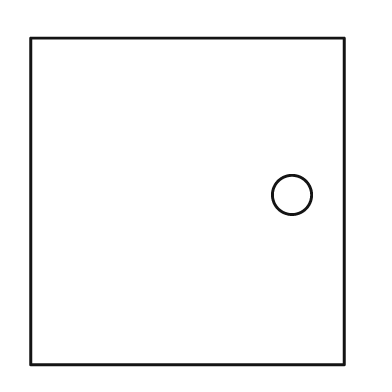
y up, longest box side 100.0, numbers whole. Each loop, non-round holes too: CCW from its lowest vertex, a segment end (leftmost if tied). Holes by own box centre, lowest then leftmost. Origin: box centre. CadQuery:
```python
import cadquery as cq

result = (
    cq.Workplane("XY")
    .moveTo(-48.0, -50.0)
    .lineTo(48.0, -50.0)
    .lineTo(48.0, 50.0)
    .lineTo(-48.0, 50.0)
    .close()
    .moveTo(32.0, 2.0)
    .circle(6.0)
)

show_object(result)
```